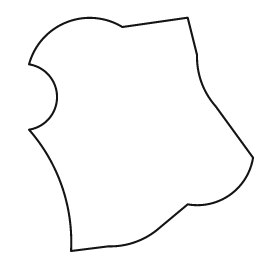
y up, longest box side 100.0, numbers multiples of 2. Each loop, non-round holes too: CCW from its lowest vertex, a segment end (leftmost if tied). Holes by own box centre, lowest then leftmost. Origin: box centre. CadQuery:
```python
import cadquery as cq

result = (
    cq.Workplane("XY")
    .moveTo(-30.0, -50.0)
    .lineTo(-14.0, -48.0)
    .threePointArc((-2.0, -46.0), (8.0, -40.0))
    .lineTo(20.0, -30.0)
    .threePointArc((38.0, -26.0), (48.0, -10.0))
    .lineTo(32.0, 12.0)
    .threePointArc((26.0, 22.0), (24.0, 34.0))
    .lineTo(20.0, 50.0)
    .lineTo(-8.0, 46.0)
    .threePointArc((-32.0, 48.0), (-48.0, 30.0))
    .threePointArc((-36.0, 16.0), (-48.0, 2.0))
    .threePointArc((-34.0, -22.0), (-30.0, -50.0))
    .close()
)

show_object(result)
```